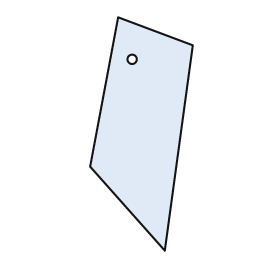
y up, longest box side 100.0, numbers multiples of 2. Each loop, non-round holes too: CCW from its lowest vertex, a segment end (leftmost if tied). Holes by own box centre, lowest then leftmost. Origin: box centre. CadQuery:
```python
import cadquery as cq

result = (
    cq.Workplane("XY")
    .moveTo(10.0, -50.0)
    .lineTo(22.0, 38.0)
    .lineTo(-10.0, 50.0)
    .lineTo(-22.0, -14.0)
    .close()
    .moveTo(-4.0, 32.0)
    .circle(2.0)
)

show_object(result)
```